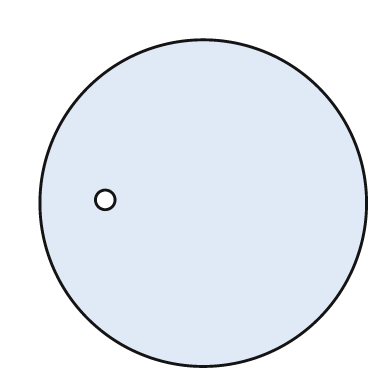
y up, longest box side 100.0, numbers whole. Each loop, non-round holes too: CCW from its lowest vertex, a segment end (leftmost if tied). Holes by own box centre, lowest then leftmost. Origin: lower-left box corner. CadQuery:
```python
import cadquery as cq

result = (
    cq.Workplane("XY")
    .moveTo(50.0, 50.0)
    .circle(50.0)
    .moveTo(20.0, 51.0)
    .circle(3.0)
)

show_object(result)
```